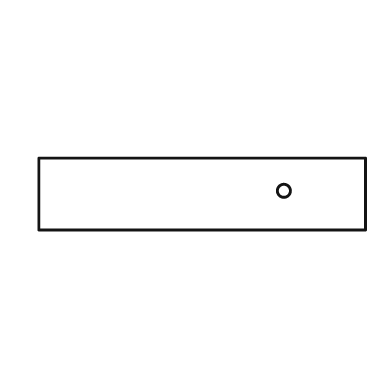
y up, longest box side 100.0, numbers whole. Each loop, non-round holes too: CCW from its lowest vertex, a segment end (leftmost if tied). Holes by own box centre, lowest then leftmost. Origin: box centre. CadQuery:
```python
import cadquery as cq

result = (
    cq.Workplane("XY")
    .moveTo(-50.0, -11.0)
    .lineTo(50.0, -11.0)
    .lineTo(50.0, 11.0)
    .lineTo(-50.0, 11.0)
    .close()
    .moveTo(25.0, 1.0)
    .circle(2.0)
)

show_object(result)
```